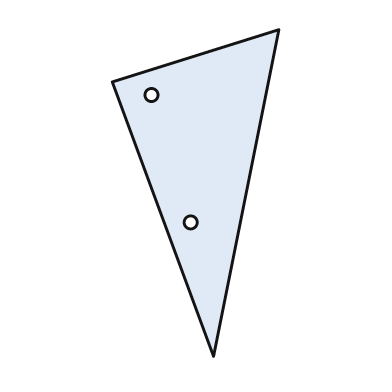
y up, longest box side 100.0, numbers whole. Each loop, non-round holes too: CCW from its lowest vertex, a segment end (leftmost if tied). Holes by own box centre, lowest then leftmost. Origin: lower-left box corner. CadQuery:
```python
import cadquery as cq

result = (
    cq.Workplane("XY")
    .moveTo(31.0, 0.0)
    .lineTo(51.0, 100.0)
    .lineTo(0.0, 84.0)
    .close()
    .moveTo(24.0, 41.0)
    .circle(2.0)
    .moveTo(12.0, 80.0)
    .circle(2.0)
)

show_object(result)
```